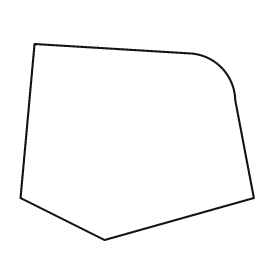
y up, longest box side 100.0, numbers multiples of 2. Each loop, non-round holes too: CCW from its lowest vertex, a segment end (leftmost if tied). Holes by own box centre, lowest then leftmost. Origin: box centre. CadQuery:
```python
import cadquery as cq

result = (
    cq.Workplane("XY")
    .moveTo(-14.0, -42.0)
    .lineTo(50.0, -24.0)
    .lineTo(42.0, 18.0)
    .threePointArc((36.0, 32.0), (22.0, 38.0))
    .lineTo(-44.0, 42.0)
    .lineTo(-50.0, -24.0)
    .close()
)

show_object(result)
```